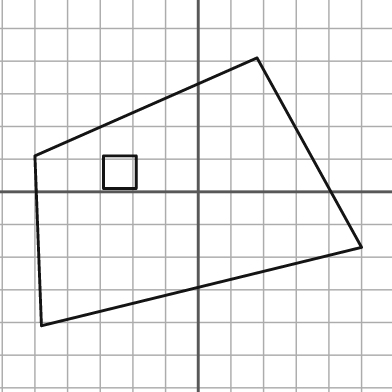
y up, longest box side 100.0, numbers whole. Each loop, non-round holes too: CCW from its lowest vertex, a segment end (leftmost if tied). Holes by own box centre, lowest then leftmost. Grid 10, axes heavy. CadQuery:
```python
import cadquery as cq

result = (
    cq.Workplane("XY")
    .moveTo(-48.0, -41.0)
    .lineTo(50.0, -17.0)
    .lineTo(18.0, 41.0)
    .lineTo(-50.0, 11.0)
    .close()
    .moveTo(-29.0, 1.0)
    .lineTo(-19.0, 1.0)
    .lineTo(-19.0, 11.0)
    .lineTo(-29.0, 11.0)
    .close()
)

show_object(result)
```